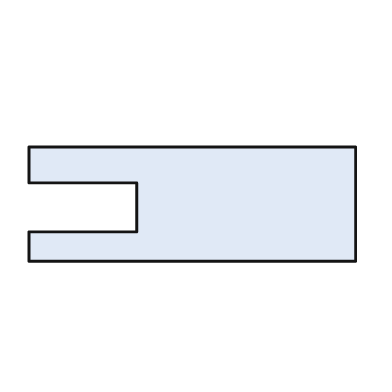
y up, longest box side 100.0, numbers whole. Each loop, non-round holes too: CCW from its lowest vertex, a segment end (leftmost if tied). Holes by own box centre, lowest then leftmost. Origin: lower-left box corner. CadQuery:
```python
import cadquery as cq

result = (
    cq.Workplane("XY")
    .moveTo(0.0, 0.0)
    .lineTo(100.0, 0.0)
    .lineTo(100.0, 35.0)
    .lineTo(0.0, 35.0)
    .lineTo(0.0, 24.0)
    .lineTo(33.0, 24.0)
    .lineTo(33.0, 9.0)
    .lineTo(0.0, 9.0)
    .close()
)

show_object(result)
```